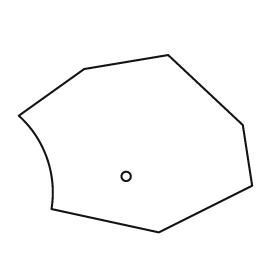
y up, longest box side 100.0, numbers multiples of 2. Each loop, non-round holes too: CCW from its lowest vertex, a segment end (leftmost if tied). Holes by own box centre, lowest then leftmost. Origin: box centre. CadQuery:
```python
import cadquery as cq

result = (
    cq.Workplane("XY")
    .moveTo(10.0, -38.0)
    .lineTo(50.0, -18.0)
    .lineTo(46.0, 8.0)
    .lineTo(14.0, 38.0)
    .lineTo(-22.0, 32.0)
    .lineTo(-50.0, 12.0)
    .threePointArc((-38.0, -6.0), (-36.0, -28.0))
    .close()
    .moveTo(-4.0, -14.0)
    .circle(2.0)
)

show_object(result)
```